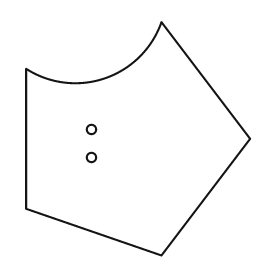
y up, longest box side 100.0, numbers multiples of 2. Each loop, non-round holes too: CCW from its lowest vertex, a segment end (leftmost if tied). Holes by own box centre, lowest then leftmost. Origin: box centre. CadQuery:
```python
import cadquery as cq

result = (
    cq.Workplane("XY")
    .moveTo(10.0, -50.0)
    .lineTo(48.0, 0.0)
    .lineTo(10.0, 50.0)
    .threePointArc((-14.0, 26.0), (-48.0, 30.0))
    .lineTo(-48.0, -30.0)
    .close()
    .moveTo(-20.0, -8.0)
    .circle(2.0)
    .moveTo(-20.0, 4.0)
    .circle(2.0)
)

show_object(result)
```